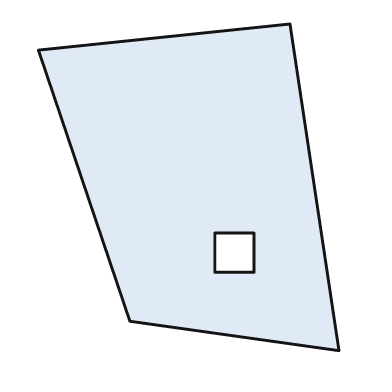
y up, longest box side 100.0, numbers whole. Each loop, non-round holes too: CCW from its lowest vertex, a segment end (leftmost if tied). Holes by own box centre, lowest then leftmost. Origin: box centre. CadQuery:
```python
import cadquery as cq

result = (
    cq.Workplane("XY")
    .moveTo(46.0, -50.0)
    .lineTo(31.0, 50.0)
    .lineTo(-46.0, 42.0)
    .lineTo(-18.0, -41.0)
    .close()
    .moveTo(8.0, -26.0)
    .lineTo(20.0, -26.0)
    .lineTo(20.0, -14.0)
    .lineTo(8.0, -14.0)
    .close()
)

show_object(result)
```